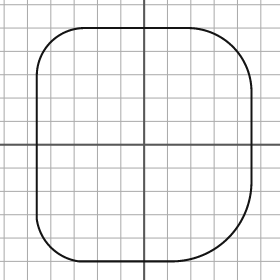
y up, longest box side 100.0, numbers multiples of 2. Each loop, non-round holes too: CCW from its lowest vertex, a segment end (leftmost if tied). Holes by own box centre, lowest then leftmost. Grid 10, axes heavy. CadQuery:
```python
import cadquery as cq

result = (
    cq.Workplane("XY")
    .moveTo(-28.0, -50.0)
    .lineTo(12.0, -50.0)
    .threePointArc((36.0, -40.0), (46.0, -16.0))
    .lineTo(46.0, 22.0)
    .threePointArc((38.0, 42.0), (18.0, 50.0))
    .lineTo(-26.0, 50.0)
    .threePointArc((-40.0, 44.0), (-46.0, 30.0))
    .lineTo(-46.0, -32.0)
    .threePointArc((-40.0, -44.0), (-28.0, -50.0))
    .close()
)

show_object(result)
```